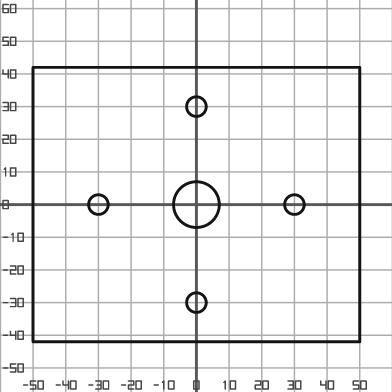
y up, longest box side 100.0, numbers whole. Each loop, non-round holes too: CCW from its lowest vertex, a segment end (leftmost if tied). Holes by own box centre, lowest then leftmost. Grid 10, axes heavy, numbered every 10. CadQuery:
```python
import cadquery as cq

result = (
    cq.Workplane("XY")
    .moveTo(-50.0, -42.0)
    .lineTo(50.0, -42.0)
    .lineTo(50.0, 42.0)
    .lineTo(-50.0, 42.0)
    .close()
    .moveTo(0.0, -30.0)
    .circle(3.0)
    .moveTo(-30.0, 0.0)
    .circle(3.0)
    .moveTo(0.0, 0.0)
    .circle(7.0)
    .moveTo(30.0, 0.0)
    .circle(3.0)
    .moveTo(0.0, 30.0)
    .circle(3.0)
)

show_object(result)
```